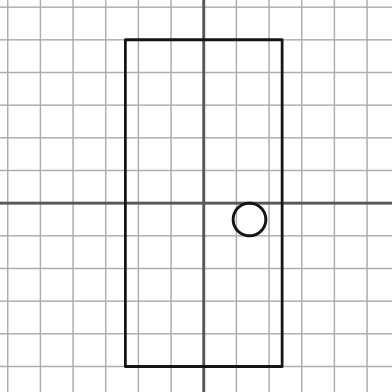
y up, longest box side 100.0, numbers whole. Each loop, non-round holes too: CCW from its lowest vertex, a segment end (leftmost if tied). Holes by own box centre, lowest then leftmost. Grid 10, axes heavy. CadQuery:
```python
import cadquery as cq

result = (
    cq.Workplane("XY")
    .moveTo(-24.0, -50.0)
    .lineTo(24.0, -50.0)
    .lineTo(24.0, 50.0)
    .lineTo(-24.0, 50.0)
    .close()
    .moveTo(14.0, -5.0)
    .circle(5.0)
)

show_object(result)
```